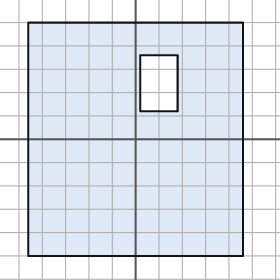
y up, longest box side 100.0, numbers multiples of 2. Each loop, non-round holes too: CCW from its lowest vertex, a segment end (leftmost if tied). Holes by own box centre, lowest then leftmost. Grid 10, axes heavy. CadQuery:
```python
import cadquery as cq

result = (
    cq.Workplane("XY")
    .moveTo(-46.0, -50.0)
    .lineTo(46.0, -50.0)
    .lineTo(46.0, 50.0)
    .lineTo(-46.0, 50.0)
    .close()
    .moveTo(2.0, 12.0)
    .lineTo(18.0, 12.0)
    .lineTo(18.0, 36.0)
    .lineTo(2.0, 36.0)
    .close()
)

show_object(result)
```